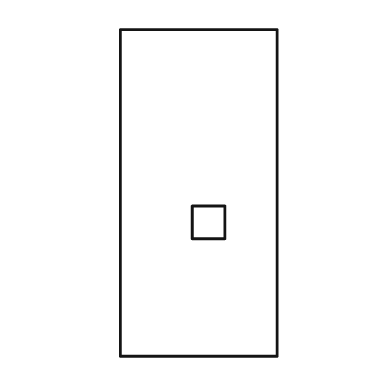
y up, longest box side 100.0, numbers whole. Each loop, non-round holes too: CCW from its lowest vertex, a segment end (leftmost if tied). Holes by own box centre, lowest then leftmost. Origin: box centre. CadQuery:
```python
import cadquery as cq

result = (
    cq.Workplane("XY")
    .moveTo(-24.0, -50.0)
    .lineTo(24.0, -50.0)
    .lineTo(24.0, 50.0)
    .lineTo(-24.0, 50.0)
    .close()
    .moveTo(-2.0, -14.0)
    .lineTo(8.0, -14.0)
    .lineTo(8.0, -4.0)
    .lineTo(-2.0, -4.0)
    .close()
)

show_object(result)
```